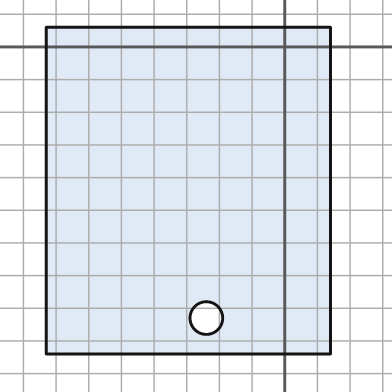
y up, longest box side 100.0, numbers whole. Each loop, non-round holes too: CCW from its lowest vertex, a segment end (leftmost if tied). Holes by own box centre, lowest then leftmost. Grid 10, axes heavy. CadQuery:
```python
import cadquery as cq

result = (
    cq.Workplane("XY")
    .moveTo(-73.0, -94.0)
    .lineTo(14.0, -94.0)
    .lineTo(14.0, 6.0)
    .lineTo(-73.0, 6.0)
    .close()
    .moveTo(-24.0, -83.0)
    .circle(5.0)
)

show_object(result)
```